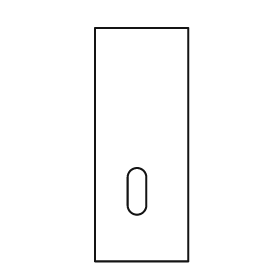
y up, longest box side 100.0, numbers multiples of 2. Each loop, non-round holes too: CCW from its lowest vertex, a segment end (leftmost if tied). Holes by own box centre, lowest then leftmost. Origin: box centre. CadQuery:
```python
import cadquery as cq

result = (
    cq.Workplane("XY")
    .moveTo(-20.0, -50.0)
    .lineTo(20.0, -50.0)
    .lineTo(20.0, 50.0)
    .lineTo(-20.0, 50.0)
    .close()
    .moveTo(-6.0, -26.0)
    .threePointArc((-2.0, -30.0), (2.0, -26.0))
    .lineTo(2.0, -14.0)
    .threePointArc((-2.0, -10.0), (-6.0, -14.0))
    .close()
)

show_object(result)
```